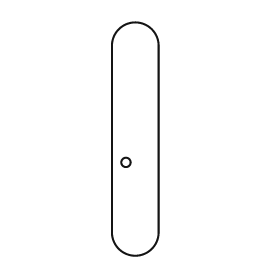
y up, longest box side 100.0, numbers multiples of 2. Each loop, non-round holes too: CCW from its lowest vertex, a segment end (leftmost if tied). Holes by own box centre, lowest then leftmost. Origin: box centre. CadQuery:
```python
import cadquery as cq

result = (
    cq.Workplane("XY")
    .moveTo(-10.0, -40.0)
    .threePointArc((0.0, -50.0), (10.0, -40.0))
    .lineTo(10.0, 40.0)
    .threePointArc((0.0, 50.0), (-10.0, 40.0))
    .close()
    .moveTo(-4.0, -10.0)
    .circle(2.0)
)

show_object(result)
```